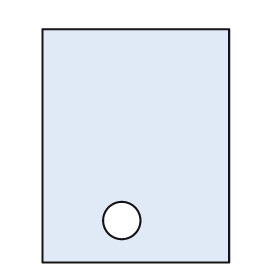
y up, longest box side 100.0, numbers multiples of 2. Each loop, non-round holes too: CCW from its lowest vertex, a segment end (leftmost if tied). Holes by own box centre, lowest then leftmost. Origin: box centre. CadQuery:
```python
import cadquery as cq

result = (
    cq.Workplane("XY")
    .moveTo(-40.0, -50.0)
    .lineTo(40.0, -50.0)
    .lineTo(40.0, 50.0)
    .lineTo(-40.0, 50.0)
    .close()
    .moveTo(-6.0, -32.0)
    .circle(8.0)
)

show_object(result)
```